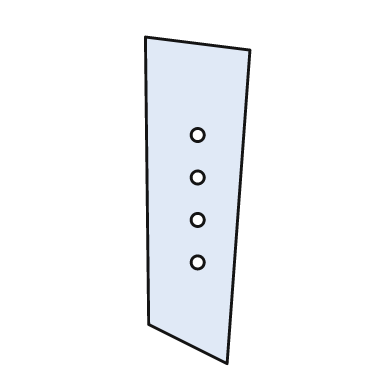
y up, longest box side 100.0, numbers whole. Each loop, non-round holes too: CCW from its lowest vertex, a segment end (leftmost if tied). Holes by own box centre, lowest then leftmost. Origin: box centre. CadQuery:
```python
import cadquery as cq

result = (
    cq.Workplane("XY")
    .moveTo(9.0, -50.0)
    .lineTo(16.0, 46.0)
    .lineTo(-16.0, 50.0)
    .lineTo(-15.0, -38.0)
    .close()
    .moveTo(0.0, -19.0)
    .circle(2.0)
    .moveTo(0.0, -6.0)
    .circle(2.0)
    .moveTo(0.0, 7.0)
    .circle(2.0)
    .moveTo(0.0, 20.0)
    .circle(2.0)
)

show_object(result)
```